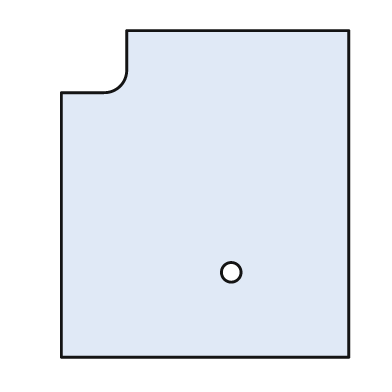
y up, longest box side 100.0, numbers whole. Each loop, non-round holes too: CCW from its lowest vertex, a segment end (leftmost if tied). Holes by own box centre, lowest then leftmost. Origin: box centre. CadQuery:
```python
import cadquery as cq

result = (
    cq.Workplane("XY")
    .moveTo(-44.0, -50.0)
    .lineTo(44.0, -50.0)
    .lineTo(44.0, 50.0)
    .lineTo(-24.0, 50.0)
    .lineTo(-24.0, 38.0)
    .threePointArc((-26.0, 33.0), (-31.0, 31.0))
    .lineTo(-44.0, 31.0)
    .close()
    .moveTo(8.0, -24.0)
    .circle(3.0)
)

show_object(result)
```